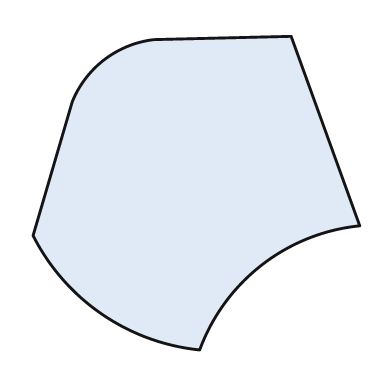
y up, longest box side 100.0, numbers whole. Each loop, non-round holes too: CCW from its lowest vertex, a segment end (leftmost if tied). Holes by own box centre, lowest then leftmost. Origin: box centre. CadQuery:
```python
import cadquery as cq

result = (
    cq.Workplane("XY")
    .moveTo(1.0, -48.0)
    .threePointArc((20.0, -22.0), (50.0, -10.0))
    .lineTo(29.0, 48.0)
    .lineTo(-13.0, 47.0)
    .threePointArc((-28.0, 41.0), (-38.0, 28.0))
    .lineTo(-50.0, -13.0)
    .threePointArc((-29.0, -37.0), (1.0, -48.0))
    .close()
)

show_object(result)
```